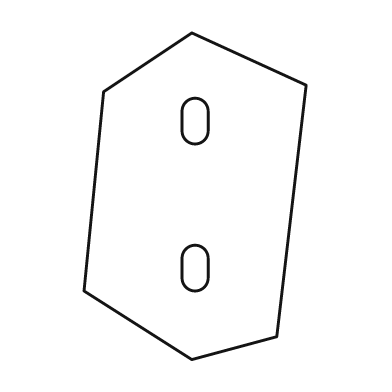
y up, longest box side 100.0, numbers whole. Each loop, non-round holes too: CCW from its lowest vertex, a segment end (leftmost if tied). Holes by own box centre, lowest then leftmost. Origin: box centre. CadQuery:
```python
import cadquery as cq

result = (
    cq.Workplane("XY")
    .moveTo(-1.0, -50.0)
    .lineTo(25.0, -43.0)
    .lineTo(34.0, 34.0)
    .lineTo(-1.0, 50.0)
    .lineTo(-28.0, 32.0)
    .lineTo(-34.0, -29.0)
    .close()
    .moveTo(-4.0, -25.0)
    .threePointArc((0.0, -29.0), (4.0, -25.0))
    .lineTo(4.0, -19.0)
    .threePointArc((0.0, -15.0), (-4.0, -19.0))
    .close()
    .moveTo(-4.0, 20.0)
    .threePointArc((0.0, 16.0), (4.0, 20.0))
    .lineTo(4.0, 26.0)
    .threePointArc((0.0, 30.0), (-4.0, 26.0))
    .close()
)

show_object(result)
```